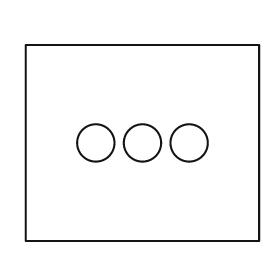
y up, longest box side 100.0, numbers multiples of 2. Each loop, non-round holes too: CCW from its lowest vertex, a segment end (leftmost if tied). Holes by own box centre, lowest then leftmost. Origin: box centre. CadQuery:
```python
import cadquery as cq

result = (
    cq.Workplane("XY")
    .moveTo(-50.0, -42.0)
    .lineTo(50.0, -42.0)
    .lineTo(50.0, 42.0)
    .lineTo(-50.0, 42.0)
    .close()
    .moveTo(-20.0, 0.0)
    .circle(8.0)
    .moveTo(0.0, 0.0)
    .circle(8.0)
    .moveTo(20.0, 0.0)
    .circle(8.0)
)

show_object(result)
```